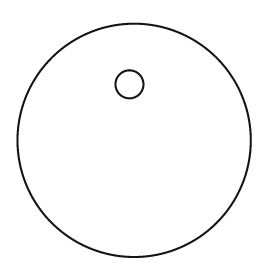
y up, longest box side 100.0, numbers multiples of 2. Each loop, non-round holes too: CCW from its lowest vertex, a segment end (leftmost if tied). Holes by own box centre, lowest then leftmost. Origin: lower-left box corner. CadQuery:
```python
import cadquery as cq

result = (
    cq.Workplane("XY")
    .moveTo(50.0, 50.0)
    .circle(50.0)
    .moveTo(48.0, 74.0)
    .circle(6.0)
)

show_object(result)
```